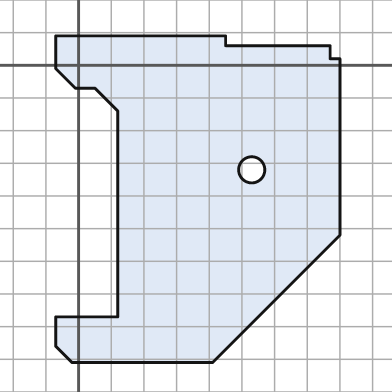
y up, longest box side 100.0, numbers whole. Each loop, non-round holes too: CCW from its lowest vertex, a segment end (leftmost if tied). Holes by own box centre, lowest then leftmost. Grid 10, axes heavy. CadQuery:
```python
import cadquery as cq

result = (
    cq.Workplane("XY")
    .moveTo(-2.0, -91.0)
    .lineTo(41.0, -91.0)
    .lineTo(80.0, -52.0)
    .lineTo(80.0, 2.0)
    .lineTo(77.0, 2.0)
    .lineTo(77.0, 6.0)
    .lineTo(45.0, 6.0)
    .lineTo(45.0, 9.0)
    .lineTo(-7.0, 9.0)
    .lineTo(-7.0, -1.0)
    .lineTo(-1.0, -7.0)
    .lineTo(5.0, -7.0)
    .lineTo(12.0, -14.0)
    .lineTo(12.0, -77.0)
    .lineTo(-7.0, -77.0)
    .lineTo(-7.0, -86.0)
    .close()
    .moveTo(53.0, -32.0)
    .circle(4.0)
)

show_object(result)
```